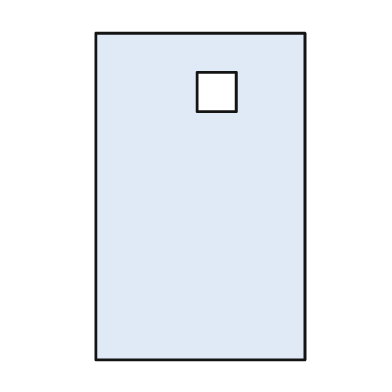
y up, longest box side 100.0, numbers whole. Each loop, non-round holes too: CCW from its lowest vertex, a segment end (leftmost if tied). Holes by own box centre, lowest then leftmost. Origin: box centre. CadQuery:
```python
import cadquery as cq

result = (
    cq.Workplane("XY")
    .moveTo(-32.0, -50.0)
    .lineTo(32.0, -50.0)
    .lineTo(32.0, 50.0)
    .lineTo(-32.0, 50.0)
    .close()
    .moveTo(-1.0, 26.0)
    .lineTo(11.0, 26.0)
    .lineTo(11.0, 38.0)
    .lineTo(-1.0, 38.0)
    .close()
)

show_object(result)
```